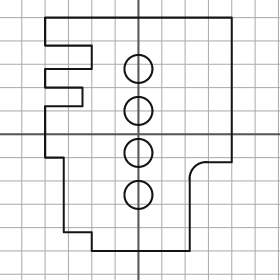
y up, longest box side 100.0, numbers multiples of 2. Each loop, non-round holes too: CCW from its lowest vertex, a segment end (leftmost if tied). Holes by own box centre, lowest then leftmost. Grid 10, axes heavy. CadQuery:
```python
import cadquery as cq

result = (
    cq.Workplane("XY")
    .moveTo(-20.0, -50.0)
    .lineTo(22.0, -50.0)
    .lineTo(22.0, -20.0)
    .threePointArc((24.0, -14.0), (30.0, -12.0))
    .lineTo(40.0, -12.0)
    .lineTo(40.0, 50.0)
    .lineTo(-40.0, 50.0)
    .lineTo(-40.0, 38.0)
    .lineTo(-20.0, 38.0)
    .lineTo(-20.0, 28.0)
    .lineTo(-40.0, 28.0)
    .lineTo(-40.0, 20.0)
    .lineTo(-24.0, 20.0)
    .lineTo(-24.0, 12.0)
    .lineTo(-40.0, 12.0)
    .lineTo(-40.0, -10.0)
    .lineTo(-32.0, -10.0)
    .lineTo(-32.0, -42.0)
    .lineTo(-20.0, -42.0)
    .close()
    .moveTo(0.0, -26.0)
    .circle(6.0)
    .moveTo(0.0, -8.0)
    .circle(6.0)
    .moveTo(0.0, 10.0)
    .circle(6.0)
    .moveTo(0.0, 28.0)
    .circle(6.0)
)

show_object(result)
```